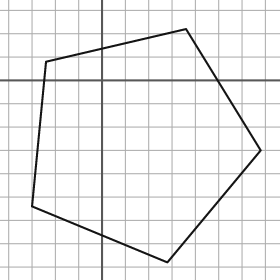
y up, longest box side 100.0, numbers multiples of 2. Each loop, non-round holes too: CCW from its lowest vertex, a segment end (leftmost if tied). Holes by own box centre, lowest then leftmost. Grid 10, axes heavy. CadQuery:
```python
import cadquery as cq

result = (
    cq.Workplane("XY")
    .moveTo(28.0, -78.0)
    .lineTo(68.0, -30.0)
    .lineTo(36.0, 22.0)
    .lineTo(-24.0, 8.0)
    .lineTo(-30.0, -54.0)
    .close()
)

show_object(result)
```